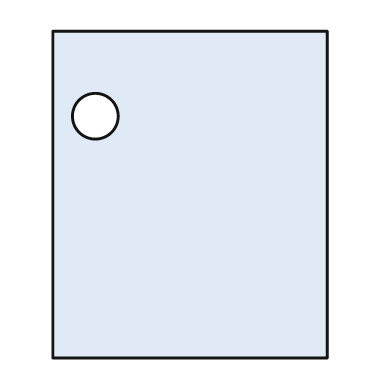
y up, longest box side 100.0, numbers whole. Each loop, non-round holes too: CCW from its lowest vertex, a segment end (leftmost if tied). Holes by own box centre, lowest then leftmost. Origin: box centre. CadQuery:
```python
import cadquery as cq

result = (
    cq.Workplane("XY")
    .moveTo(-42.0, -50.0)
    .lineTo(42.0, -50.0)
    .lineTo(42.0, 50.0)
    .lineTo(-42.0, 50.0)
    .close()
    .moveTo(-29.0, 24.0)
    .circle(7.0)
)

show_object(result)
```